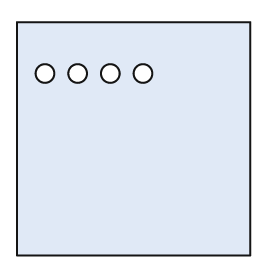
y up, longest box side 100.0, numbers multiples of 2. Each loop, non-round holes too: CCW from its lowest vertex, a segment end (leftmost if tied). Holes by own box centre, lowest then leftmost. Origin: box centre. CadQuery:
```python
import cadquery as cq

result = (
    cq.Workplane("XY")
    .moveTo(-50.0, -50.0)
    .lineTo(50.0, -50.0)
    .lineTo(50.0, 50.0)
    .lineTo(-50.0, 50.0)
    .close()
    .moveTo(-38.0, 28.0)
    .circle(4.0)
    .moveTo(-24.0, 28.0)
    .circle(4.0)
    .moveTo(-10.0, 28.0)
    .circle(4.0)
    .moveTo(4.0, 28.0)
    .circle(4.0)
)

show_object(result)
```